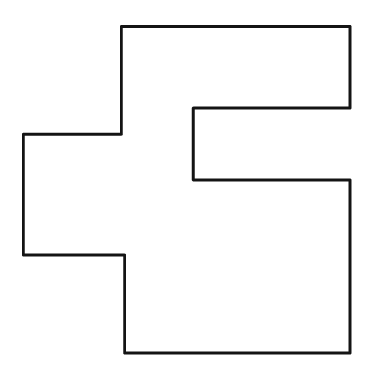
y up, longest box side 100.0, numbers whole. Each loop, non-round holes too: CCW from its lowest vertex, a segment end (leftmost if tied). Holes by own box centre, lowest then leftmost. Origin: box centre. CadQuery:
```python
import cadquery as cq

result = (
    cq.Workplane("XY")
    .moveTo(-19.0, -50.0)
    .lineTo(50.0, -50.0)
    .lineTo(50.0, 3.0)
    .lineTo(2.0, 3.0)
    .lineTo(2.0, 25.0)
    .lineTo(50.0, 25.0)
    .lineTo(50.0, 50.0)
    .lineTo(-20.0, 50.0)
    .lineTo(-20.0, 17.0)
    .lineTo(-50.0, 17.0)
    .lineTo(-50.0, -20.0)
    .lineTo(-19.0, -20.0)
    .close()
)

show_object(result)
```